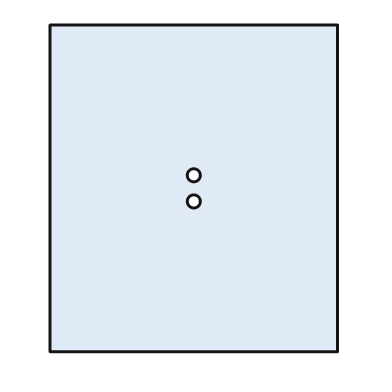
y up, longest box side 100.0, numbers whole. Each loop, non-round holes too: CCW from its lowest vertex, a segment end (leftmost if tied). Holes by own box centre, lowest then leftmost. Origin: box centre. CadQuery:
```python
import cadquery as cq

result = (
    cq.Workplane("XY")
    .moveTo(-44.0, -50.0)
    .lineTo(44.0, -50.0)
    .lineTo(44.0, 50.0)
    .lineTo(-44.0, 50.0)
    .close()
    .moveTo(0.0, -4.0)
    .circle(2.0)
    .moveTo(0.0, 4.0)
    .circle(2.0)
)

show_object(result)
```